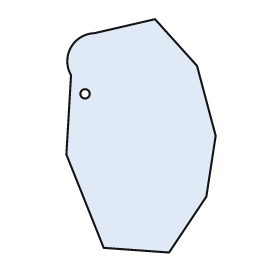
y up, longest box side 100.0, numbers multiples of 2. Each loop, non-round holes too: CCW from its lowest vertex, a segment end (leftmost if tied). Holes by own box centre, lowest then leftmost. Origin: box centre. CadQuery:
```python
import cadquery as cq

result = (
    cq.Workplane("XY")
    .moveTo(12.0, -50.0)
    .lineTo(28.0, -26.0)
    .lineTo(32.0, 0.0)
    .lineTo(24.0, 30.0)
    .lineTo(6.0, 50.0)
    .lineTo(-20.0, 44.0)
    .threePointArc((-30.0, 38.0), (-30.0, 26.0))
    .lineTo(-32.0, -8.0)
    .lineTo(-16.0, -48.0)
    .close()
    .moveTo(-24.0, 18.0)
    .circle(2.0)
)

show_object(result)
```